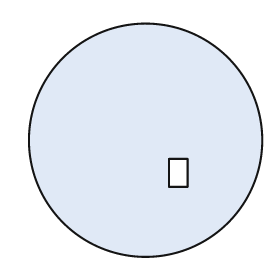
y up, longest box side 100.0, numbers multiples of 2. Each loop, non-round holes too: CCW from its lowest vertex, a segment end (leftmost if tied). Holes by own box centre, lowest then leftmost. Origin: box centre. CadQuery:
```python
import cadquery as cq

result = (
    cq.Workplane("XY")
    .moveTo(0.0, 0.0)
    .circle(50.0)
    .moveTo(10.0, -20.0)
    .lineTo(18.0, -20.0)
    .lineTo(18.0, -8.0)
    .lineTo(10.0, -8.0)
    .close()
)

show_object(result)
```